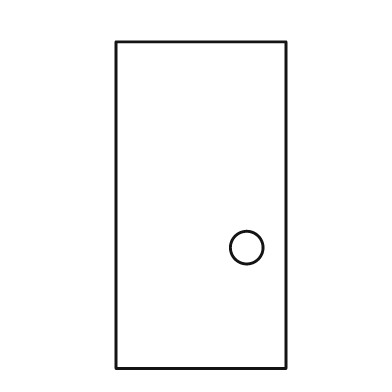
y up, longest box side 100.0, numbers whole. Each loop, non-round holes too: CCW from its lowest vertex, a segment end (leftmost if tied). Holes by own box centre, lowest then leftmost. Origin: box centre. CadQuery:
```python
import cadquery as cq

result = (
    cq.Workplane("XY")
    .moveTo(-26.0, -50.0)
    .lineTo(26.0, -50.0)
    .lineTo(26.0, 50.0)
    .lineTo(-26.0, 50.0)
    .close()
    .moveTo(14.0, -13.0)
    .circle(5.0)
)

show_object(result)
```